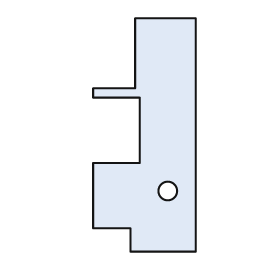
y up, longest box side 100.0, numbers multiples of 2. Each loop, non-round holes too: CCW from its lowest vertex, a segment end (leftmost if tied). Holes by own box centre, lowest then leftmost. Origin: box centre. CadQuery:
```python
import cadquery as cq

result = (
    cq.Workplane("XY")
    .moveTo(-6.0, -50.0)
    .lineTo(22.0, -50.0)
    .lineTo(22.0, 50.0)
    .lineTo(-4.0, 50.0)
    .lineTo(-4.0, 20.0)
    .lineTo(-22.0, 20.0)
    .lineTo(-22.0, 16.0)
    .lineTo(-2.0, 16.0)
    .lineTo(-2.0, -12.0)
    .lineTo(-22.0, -12.0)
    .lineTo(-22.0, -40.0)
    .lineTo(-6.0, -40.0)
    .close()
    .moveTo(10.0, -24.0)
    .circle(4.0)
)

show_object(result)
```